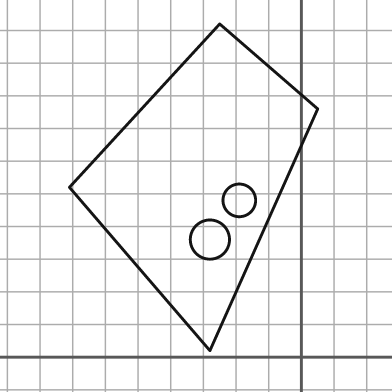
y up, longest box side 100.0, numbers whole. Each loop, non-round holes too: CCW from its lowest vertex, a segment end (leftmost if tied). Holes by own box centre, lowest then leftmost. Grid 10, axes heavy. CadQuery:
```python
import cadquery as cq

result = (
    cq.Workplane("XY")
    .moveTo(-28.0, 2.0)
    .lineTo(5.0, 76.0)
    .lineTo(-25.0, 102.0)
    .lineTo(-71.0, 52.0)
    .close()
    .moveTo(-28.0, 36.0)
    .circle(6.0)
    .moveTo(-19.0, 48.0)
    .circle(5.0)
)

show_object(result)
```